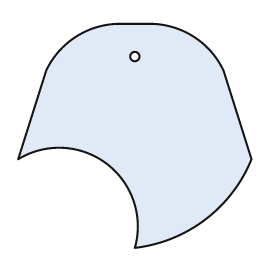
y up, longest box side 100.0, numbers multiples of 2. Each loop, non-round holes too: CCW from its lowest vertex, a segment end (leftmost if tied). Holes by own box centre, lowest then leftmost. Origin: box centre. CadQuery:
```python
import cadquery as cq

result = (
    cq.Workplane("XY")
    .moveTo(0.0, -48.0)
    .threePointArc((30.0, -36.0), (50.0, -10.0))
    .lineTo(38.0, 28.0)
    .threePointArc((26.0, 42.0), (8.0, 48.0))
    .lineTo(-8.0, 48.0)
    .threePointArc((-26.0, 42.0), (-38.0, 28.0))
    .lineTo(-50.0, -10.0)
    .threePointArc((-12.0, -12.0), (0.0, -48.0))
    .close()
    .moveTo(0.0, 34.0)
    .circle(2.0)
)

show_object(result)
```